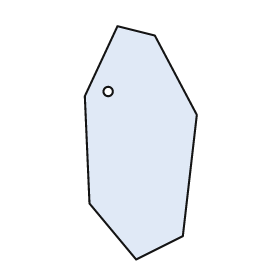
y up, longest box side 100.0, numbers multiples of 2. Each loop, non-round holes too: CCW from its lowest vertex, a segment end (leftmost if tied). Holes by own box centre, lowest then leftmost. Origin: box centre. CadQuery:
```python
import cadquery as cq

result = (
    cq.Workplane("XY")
    .moveTo(-2.0, -50.0)
    .lineTo(18.0, -40.0)
    .lineTo(24.0, 12.0)
    .lineTo(6.0, 46.0)
    .lineTo(-10.0, 50.0)
    .lineTo(-24.0, 20.0)
    .lineTo(-22.0, -26.0)
    .close()
    .moveTo(-14.0, 22.0)
    .circle(2.0)
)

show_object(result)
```